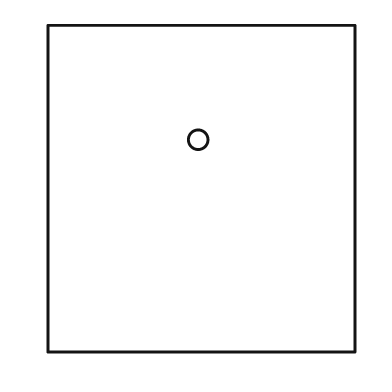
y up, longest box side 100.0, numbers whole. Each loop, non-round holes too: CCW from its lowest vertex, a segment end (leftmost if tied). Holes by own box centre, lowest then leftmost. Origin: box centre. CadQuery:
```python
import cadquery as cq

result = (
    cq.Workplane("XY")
    .moveTo(-47.0, -50.0)
    .lineTo(47.0, -50.0)
    .lineTo(47.0, 50.0)
    .lineTo(-47.0, 50.0)
    .close()
    .moveTo(-1.0, 15.0)
    .circle(3.0)
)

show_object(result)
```